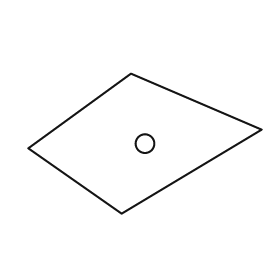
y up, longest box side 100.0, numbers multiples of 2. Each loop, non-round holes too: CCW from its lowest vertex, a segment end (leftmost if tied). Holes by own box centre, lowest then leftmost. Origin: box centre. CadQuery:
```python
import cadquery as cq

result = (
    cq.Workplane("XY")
    .moveTo(-10.0, -30.0)
    .lineTo(50.0, 6.0)
    .lineTo(-6.0, 30.0)
    .lineTo(-50.0, -2.0)
    .close()
    .moveTo(0.0, 0.0)
    .circle(4.0)
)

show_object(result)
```